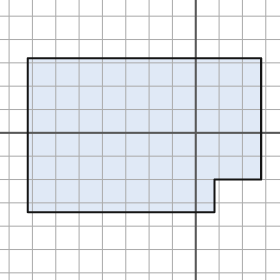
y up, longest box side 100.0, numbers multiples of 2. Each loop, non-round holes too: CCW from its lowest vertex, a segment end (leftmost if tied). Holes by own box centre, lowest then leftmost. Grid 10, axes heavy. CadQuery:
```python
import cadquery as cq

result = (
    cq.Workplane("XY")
    .moveTo(-72.0, -34.0)
    .lineTo(8.0, -34.0)
    .lineTo(8.0, -20.0)
    .lineTo(28.0, -20.0)
    .lineTo(28.0, 32.0)
    .lineTo(-72.0, 32.0)
    .close()
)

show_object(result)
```